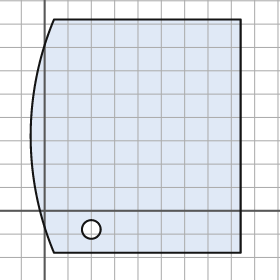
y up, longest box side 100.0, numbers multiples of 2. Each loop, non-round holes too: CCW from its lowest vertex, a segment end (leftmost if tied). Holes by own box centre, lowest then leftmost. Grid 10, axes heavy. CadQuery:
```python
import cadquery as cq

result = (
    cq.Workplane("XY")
    .moveTo(4.0, -18.0)
    .lineTo(84.0, -18.0)
    .lineTo(84.0, 82.0)
    .lineTo(4.0, 82.0)
    .threePointArc((-6.0, 32.0), (4.0, -18.0))
    .close()
    .moveTo(20.0, -8.0)
    .circle(4.0)
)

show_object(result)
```